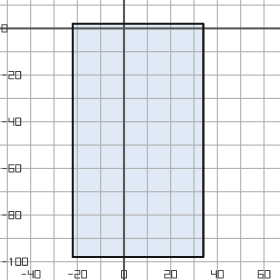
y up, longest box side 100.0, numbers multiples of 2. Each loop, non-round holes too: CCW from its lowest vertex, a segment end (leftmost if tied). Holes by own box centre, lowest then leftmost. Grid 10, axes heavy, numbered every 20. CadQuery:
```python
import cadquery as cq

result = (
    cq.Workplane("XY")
    .moveTo(-22.0, -98.0)
    .lineTo(34.0, -98.0)
    .lineTo(34.0, 2.0)
    .lineTo(-22.0, 2.0)
    .close()
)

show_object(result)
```